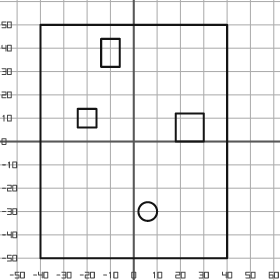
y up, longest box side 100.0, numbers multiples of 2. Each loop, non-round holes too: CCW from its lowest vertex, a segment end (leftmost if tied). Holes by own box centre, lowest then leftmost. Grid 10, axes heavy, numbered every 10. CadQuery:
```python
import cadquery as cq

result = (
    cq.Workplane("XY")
    .moveTo(-40.0, -50.0)
    .lineTo(40.0, -50.0)
    .lineTo(40.0, 50.0)
    .lineTo(-40.0, 50.0)
    .close()
    .moveTo(6.0, -30.0)
    .circle(4.0)
    .moveTo(18.0, 0.0)
    .lineTo(30.0, 0.0)
    .lineTo(30.0, 12.0)
    .lineTo(18.0, 12.0)
    .close()
    .moveTo(-24.0, 6.0)
    .lineTo(-16.0, 6.0)
    .lineTo(-16.0, 14.0)
    .lineTo(-24.0, 14.0)
    .close()
    .moveTo(-14.0, 32.0)
    .lineTo(-6.0, 32.0)
    .lineTo(-6.0, 44.0)
    .lineTo(-14.0, 44.0)
    .close()
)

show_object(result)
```